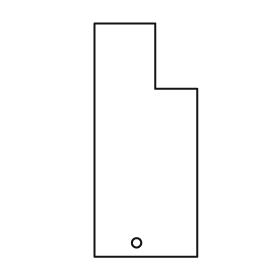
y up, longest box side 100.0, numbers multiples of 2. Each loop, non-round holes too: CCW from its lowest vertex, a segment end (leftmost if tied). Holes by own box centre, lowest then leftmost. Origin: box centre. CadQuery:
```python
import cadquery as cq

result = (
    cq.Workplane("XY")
    .moveTo(-22.0, -50.0)
    .lineTo(22.0, -50.0)
    .lineTo(22.0, 22.0)
    .lineTo(4.0, 22.0)
    .lineTo(4.0, 50.0)
    .lineTo(-22.0, 50.0)
    .close()
    .moveTo(-4.0, -44.0)
    .circle(2.0)
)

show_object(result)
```